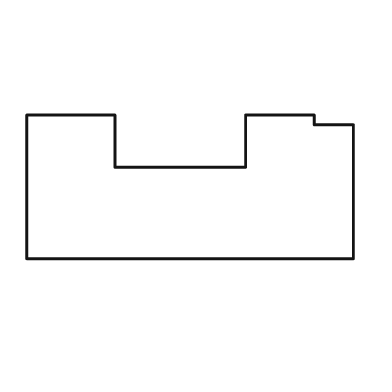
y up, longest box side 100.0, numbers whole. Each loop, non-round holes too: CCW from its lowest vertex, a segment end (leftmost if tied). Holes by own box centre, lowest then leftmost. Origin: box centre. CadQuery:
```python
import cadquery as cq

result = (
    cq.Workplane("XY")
    .moveTo(-50.0, -22.0)
    .lineTo(50.0, -22.0)
    .lineTo(50.0, 19.0)
    .lineTo(38.0, 19.0)
    .lineTo(38.0, 22.0)
    .lineTo(17.0, 22.0)
    .lineTo(17.0, 6.0)
    .lineTo(-23.0, 6.0)
    .lineTo(-23.0, 22.0)
    .lineTo(-50.0, 22.0)
    .close()
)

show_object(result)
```